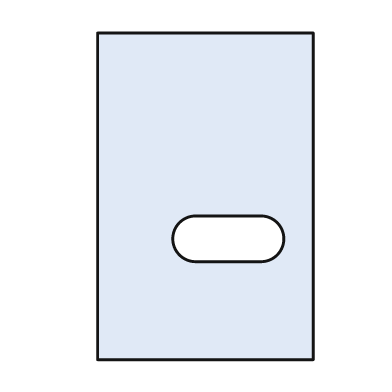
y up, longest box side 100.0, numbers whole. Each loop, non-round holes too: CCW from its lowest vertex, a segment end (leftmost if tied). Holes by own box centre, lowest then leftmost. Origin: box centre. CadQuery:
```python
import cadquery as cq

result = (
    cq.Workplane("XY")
    .moveTo(-33.0, -50.0)
    .lineTo(33.0, -50.0)
    .lineTo(33.0, 50.0)
    .lineTo(-33.0, 50.0)
    .close()
    .moveTo(-3.0, -20.0)
    .lineTo(17.0, -20.0)
    .threePointArc((24.0, -13.0), (17.0, -6.0))
    .lineTo(-3.0, -6.0)
    .threePointArc((-10.0, -13.0), (-3.0, -20.0))
    .close()
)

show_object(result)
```